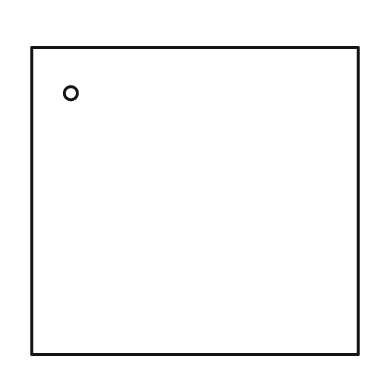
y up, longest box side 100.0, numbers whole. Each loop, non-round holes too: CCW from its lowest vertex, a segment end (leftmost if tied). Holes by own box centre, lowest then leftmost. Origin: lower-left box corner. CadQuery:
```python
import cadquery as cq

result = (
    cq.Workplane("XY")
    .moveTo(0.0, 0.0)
    .lineTo(100.0, 0.0)
    .lineTo(100.0, 94.0)
    .lineTo(0.0, 94.0)
    .close()
    .moveTo(12.0, 80.0)
    .circle(2.0)
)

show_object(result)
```